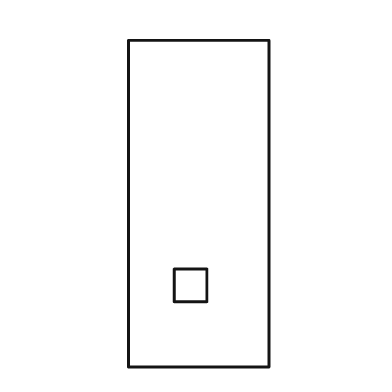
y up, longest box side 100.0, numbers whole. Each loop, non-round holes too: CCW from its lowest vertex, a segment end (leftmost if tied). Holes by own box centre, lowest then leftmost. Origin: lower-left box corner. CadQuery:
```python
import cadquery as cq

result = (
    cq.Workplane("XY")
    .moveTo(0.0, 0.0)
    .lineTo(43.0, 0.0)
    .lineTo(43.0, 100.0)
    .lineTo(0.0, 100.0)
    .close()
    .moveTo(14.0, 20.0)
    .lineTo(24.0, 20.0)
    .lineTo(24.0, 30.0)
    .lineTo(14.0, 30.0)
    .close()
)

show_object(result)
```